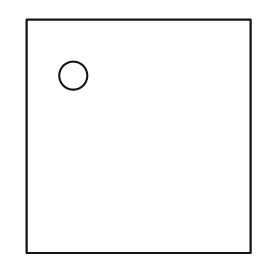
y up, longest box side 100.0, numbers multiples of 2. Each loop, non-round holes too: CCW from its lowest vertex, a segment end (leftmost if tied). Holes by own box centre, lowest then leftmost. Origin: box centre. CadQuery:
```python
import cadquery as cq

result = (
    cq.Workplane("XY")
    .moveTo(-48.0, -50.0)
    .lineTo(48.0, -50.0)
    .lineTo(48.0, 50.0)
    .lineTo(-48.0, 50.0)
    .close()
    .moveTo(-28.0, 26.0)
    .circle(6.0)
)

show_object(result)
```